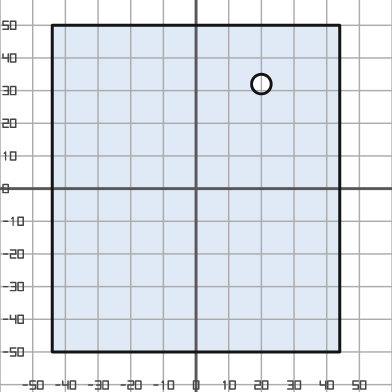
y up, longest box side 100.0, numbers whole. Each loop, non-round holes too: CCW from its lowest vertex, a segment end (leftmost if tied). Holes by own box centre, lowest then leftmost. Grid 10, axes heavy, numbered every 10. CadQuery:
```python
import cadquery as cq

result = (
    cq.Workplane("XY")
    .moveTo(-44.0, -50.0)
    .lineTo(44.0, -50.0)
    .lineTo(44.0, 50.0)
    .lineTo(-44.0, 50.0)
    .close()
    .moveTo(20.0, 32.0)
    .circle(3.0)
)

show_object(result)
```